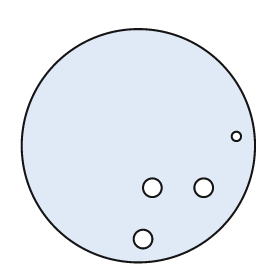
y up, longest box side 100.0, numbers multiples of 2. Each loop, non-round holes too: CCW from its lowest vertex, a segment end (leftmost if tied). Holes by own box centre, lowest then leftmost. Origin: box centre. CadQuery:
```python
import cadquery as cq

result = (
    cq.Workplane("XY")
    .moveTo(0.0, 0.0)
    .circle(50.0)
    .moveTo(2.0, -40.0)
    .circle(4.0)
    .moveTo(6.0, -18.0)
    .circle(4.0)
    .moveTo(28.0, -18.0)
    .circle(4.0)
    .moveTo(42.0, 4.0)
    .circle(2.0)
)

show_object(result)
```